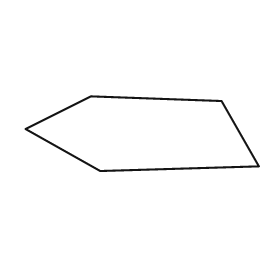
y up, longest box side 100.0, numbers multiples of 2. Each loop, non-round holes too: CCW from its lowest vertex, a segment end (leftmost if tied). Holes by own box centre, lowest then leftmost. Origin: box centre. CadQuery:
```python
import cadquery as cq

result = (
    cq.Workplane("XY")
    .moveTo(-18.0, -16.0)
    .lineTo(50.0, -14.0)
    .lineTo(34.0, 14.0)
    .lineTo(-22.0, 16.0)
    .lineTo(-50.0, 2.0)
    .close()
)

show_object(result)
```